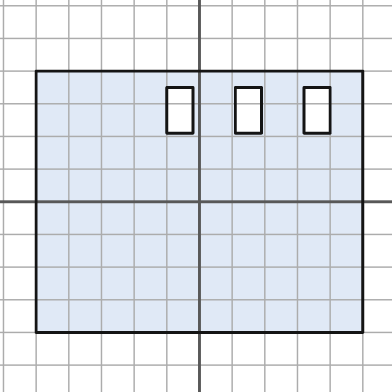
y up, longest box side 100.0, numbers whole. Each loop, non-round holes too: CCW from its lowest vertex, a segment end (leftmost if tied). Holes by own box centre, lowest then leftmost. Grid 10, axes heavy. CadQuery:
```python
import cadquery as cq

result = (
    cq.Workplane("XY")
    .moveTo(-50.0, -40.0)
    .lineTo(50.0, -40.0)
    .lineTo(50.0, 40.0)
    .lineTo(-50.0, 40.0)
    .close()
    .moveTo(-10.0, 21.0)
    .lineTo(-2.0, 21.0)
    .lineTo(-2.0, 35.0)
    .lineTo(-10.0, 35.0)
    .close()
    .moveTo(11.0, 21.0)
    .lineTo(19.0, 21.0)
    .lineTo(19.0, 35.0)
    .lineTo(11.0, 35.0)
    .close()
    .moveTo(32.0, 21.0)
    .lineTo(40.0, 21.0)
    .lineTo(40.0, 35.0)
    .lineTo(32.0, 35.0)
    .close()
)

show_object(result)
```